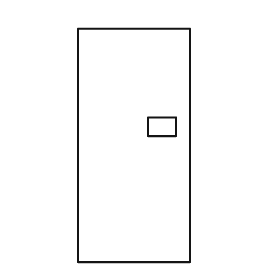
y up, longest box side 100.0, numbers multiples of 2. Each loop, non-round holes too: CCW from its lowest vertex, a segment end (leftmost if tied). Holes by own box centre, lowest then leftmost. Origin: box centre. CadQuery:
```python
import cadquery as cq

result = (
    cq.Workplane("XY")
    .moveTo(-24.0, -50.0)
    .lineTo(24.0, -50.0)
    .lineTo(24.0, 50.0)
    .lineTo(-24.0, 50.0)
    .close()
    .moveTo(6.0, 4.0)
    .lineTo(18.0, 4.0)
    .lineTo(18.0, 12.0)
    .lineTo(6.0, 12.0)
    .close()
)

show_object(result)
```